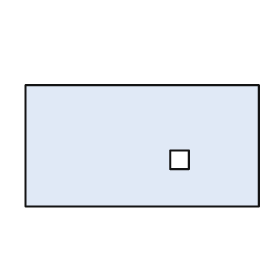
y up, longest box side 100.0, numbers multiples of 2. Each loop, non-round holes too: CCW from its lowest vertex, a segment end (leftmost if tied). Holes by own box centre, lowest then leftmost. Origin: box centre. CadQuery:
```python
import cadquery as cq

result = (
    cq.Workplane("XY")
    .moveTo(-50.0, -26.0)
    .lineTo(50.0, -26.0)
    .lineTo(50.0, 26.0)
    .lineTo(-50.0, 26.0)
    .close()
    .moveTo(12.0, -10.0)
    .lineTo(20.0, -10.0)
    .lineTo(20.0, -2.0)
    .lineTo(12.0, -2.0)
    .close()
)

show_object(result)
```